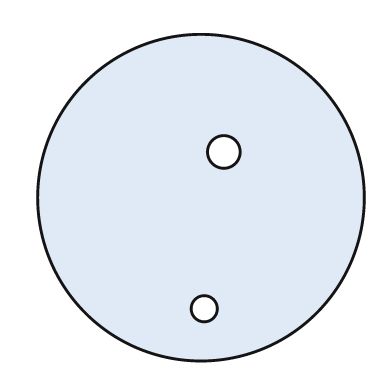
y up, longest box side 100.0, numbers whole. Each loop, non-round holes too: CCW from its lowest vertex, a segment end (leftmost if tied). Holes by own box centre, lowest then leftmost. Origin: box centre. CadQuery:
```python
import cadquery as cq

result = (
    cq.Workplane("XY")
    .moveTo(0.0, 0.0)
    .circle(50.0)
    .moveTo(1.0, -34.0)
    .circle(4.0)
    .moveTo(7.0, 14.0)
    .circle(5.0)
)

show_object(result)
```